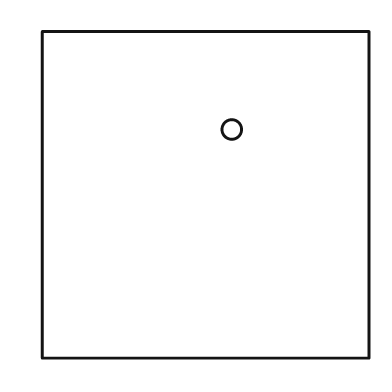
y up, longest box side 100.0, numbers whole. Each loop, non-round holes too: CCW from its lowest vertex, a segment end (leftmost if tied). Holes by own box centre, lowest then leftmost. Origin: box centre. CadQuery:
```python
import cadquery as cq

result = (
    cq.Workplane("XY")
    .moveTo(-50.0, -50.0)
    .lineTo(50.0, -50.0)
    .lineTo(50.0, 50.0)
    .lineTo(-50.0, 50.0)
    .close()
    .moveTo(8.0, 20.0)
    .circle(3.0)
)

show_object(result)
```